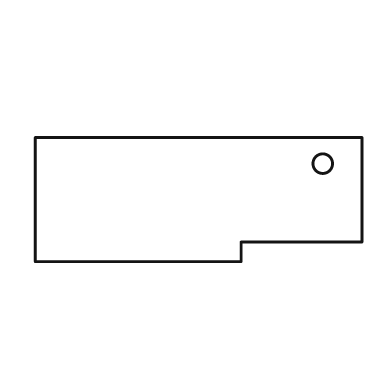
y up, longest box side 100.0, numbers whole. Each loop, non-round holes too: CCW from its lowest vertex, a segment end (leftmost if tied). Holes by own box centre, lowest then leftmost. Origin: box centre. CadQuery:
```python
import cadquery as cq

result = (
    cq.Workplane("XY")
    .moveTo(-50.0, -19.0)
    .lineTo(13.0, -19.0)
    .lineTo(13.0, -13.0)
    .lineTo(50.0, -13.0)
    .lineTo(50.0, 19.0)
    .lineTo(-50.0, 19.0)
    .close()
    .moveTo(38.0, 11.0)
    .circle(3.0)
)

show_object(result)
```